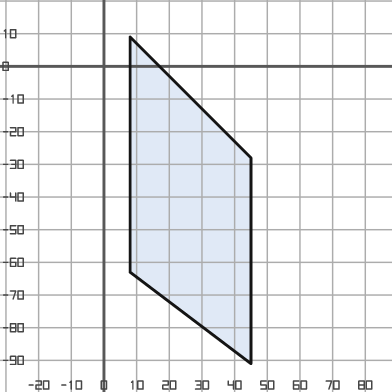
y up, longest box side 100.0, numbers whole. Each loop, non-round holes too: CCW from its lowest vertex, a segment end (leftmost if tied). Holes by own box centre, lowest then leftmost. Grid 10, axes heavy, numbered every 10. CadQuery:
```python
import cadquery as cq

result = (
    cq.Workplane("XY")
    .moveTo(45.0, -91.0)
    .lineTo(45.0, -28.0)
    .lineTo(8.0, 9.0)
    .lineTo(8.0, -63.0)
    .close()
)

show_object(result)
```